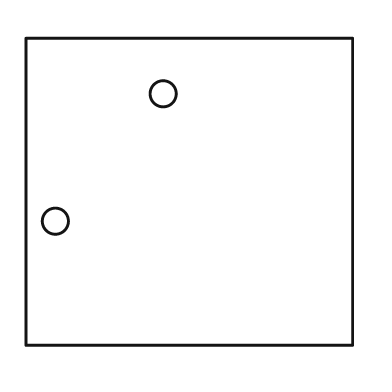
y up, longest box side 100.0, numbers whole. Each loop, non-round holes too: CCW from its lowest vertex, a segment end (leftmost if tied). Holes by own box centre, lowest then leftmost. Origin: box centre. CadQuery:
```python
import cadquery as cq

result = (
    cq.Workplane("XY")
    .moveTo(-50.0, -47.0)
    .lineTo(50.0, -47.0)
    .lineTo(50.0, 47.0)
    .lineTo(-50.0, 47.0)
    .close()
    .moveTo(-41.0, -9.0)
    .circle(4.0)
    .moveTo(-8.0, 30.0)
    .circle(4.0)
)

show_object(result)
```